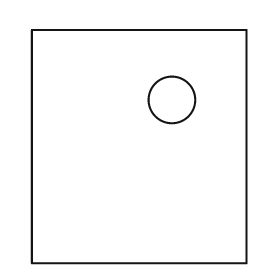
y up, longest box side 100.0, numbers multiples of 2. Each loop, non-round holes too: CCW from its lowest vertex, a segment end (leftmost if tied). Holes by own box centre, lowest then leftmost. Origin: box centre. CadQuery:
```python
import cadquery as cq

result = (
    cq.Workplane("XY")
    .moveTo(-46.0, -50.0)
    .lineTo(46.0, -50.0)
    .lineTo(46.0, 50.0)
    .lineTo(-46.0, 50.0)
    .close()
    .moveTo(14.0, 20.0)
    .circle(10.0)
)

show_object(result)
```